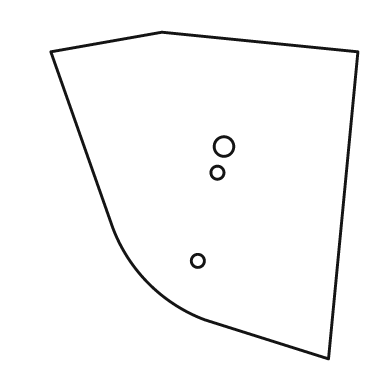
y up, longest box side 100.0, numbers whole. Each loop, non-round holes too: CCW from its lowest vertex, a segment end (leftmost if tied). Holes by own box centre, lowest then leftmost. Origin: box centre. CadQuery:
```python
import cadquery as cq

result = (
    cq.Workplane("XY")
    .moveTo(38.0, -50.0)
    .lineTo(47.0, 44.0)
    .lineTo(-13.0, 50.0)
    .lineTo(-47.0, 44.0)
    .lineTo(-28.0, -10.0)
    .threePointArc((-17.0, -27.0), (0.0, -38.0))
    .close()
    .moveTo(-2.0, -20.0)
    .circle(2.0)
    .moveTo(4.0, 7.0)
    .circle(2.0)
    .moveTo(6.0, 15.0)
    .circle(3.0)
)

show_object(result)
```